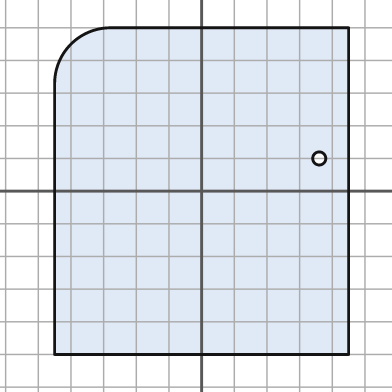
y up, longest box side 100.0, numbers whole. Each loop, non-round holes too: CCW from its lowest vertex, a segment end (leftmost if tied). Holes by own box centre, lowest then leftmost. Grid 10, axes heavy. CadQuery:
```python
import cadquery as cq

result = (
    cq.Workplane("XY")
    .moveTo(-45.0, -50.0)
    .lineTo(45.0, -50.0)
    .lineTo(45.0, 50.0)
    .lineTo(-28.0, 50.0)
    .threePointArc((-40.0, 45.0), (-45.0, 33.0))
    .close()
    .moveTo(36.0, 10.0)
    .circle(2.0)
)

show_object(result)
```